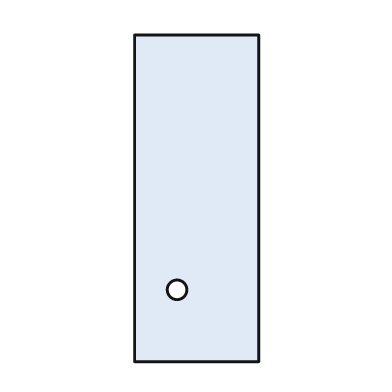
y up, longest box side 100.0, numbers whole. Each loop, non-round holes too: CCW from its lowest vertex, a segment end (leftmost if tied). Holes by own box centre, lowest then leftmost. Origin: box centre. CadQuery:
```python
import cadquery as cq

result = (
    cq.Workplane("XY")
    .moveTo(-19.0, -50.0)
    .lineTo(19.0, -50.0)
    .lineTo(19.0, 50.0)
    .lineTo(-19.0, 50.0)
    .close()
    .moveTo(-6.0, -28.0)
    .circle(3.0)
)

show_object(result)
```